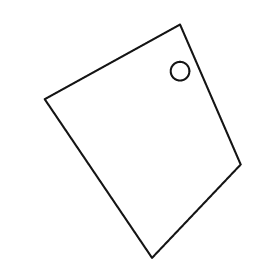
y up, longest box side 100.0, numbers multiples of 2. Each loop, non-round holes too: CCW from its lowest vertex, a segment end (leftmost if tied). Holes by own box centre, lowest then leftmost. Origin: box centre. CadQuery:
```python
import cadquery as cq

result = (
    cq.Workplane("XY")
    .moveTo(4.0, -50.0)
    .lineTo(42.0, -10.0)
    .lineTo(16.0, 50.0)
    .lineTo(-42.0, 18.0)
    .close()
    .moveTo(16.0, 30.0)
    .circle(4.0)
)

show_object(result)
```